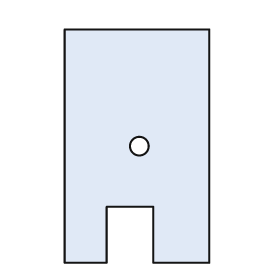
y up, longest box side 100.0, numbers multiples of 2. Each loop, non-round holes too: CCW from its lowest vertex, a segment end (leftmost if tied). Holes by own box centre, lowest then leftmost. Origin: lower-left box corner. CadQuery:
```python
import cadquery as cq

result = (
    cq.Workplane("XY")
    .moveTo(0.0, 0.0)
    .lineTo(18.0, 0.0)
    .lineTo(18.0, 24.0)
    .lineTo(38.0, 24.0)
    .lineTo(38.0, 0.0)
    .lineTo(62.0, 0.0)
    .lineTo(62.0, 100.0)
    .lineTo(0.0, 100.0)
    .close()
    .moveTo(32.0, 50.0)
    .circle(4.0)
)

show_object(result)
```